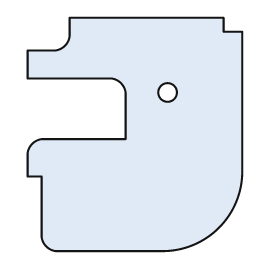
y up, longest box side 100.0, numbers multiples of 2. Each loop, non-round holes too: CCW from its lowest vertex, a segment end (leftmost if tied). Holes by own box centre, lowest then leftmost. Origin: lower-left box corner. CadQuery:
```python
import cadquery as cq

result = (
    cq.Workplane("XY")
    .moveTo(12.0, 0.0)
    .lineTo(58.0, 0.0)
    .threePointArc((82.0, 10.0), (92.0, 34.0))
    .lineTo(92.0, 94.0)
    .lineTo(84.0, 94.0)
    .lineTo(84.0, 100.0)
    .lineTo(18.0, 100.0)
    .lineTo(18.0, 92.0)
    .threePointArc((16.0, 88.0), (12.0, 86.0))
    .lineTo(0.0, 86.0)
    .lineTo(0.0, 74.0)
    .lineTo(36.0, 74.0)
    .threePointArc((40.0, 72.0), (42.0, 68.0))
    .lineTo(42.0, 48.0)
    .lineTo(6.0, 48.0)
    .threePointArc((2.0, 46.0), (0.0, 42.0))
    .lineTo(0.0, 32.0)
    .lineTo(6.0, 32.0)
    .lineTo(6.0, 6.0)
    .threePointArc((8.0, 2.0), (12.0, 0.0))
    .close()
    .moveTo(60.0, 68.0)
    .circle(4.0)
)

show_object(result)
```